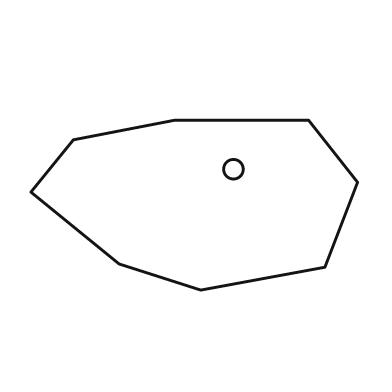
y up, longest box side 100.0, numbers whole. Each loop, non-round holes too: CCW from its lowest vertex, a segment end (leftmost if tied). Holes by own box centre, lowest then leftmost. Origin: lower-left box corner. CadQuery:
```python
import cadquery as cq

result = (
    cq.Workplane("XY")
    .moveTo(52.0, 0.0)
    .lineTo(90.0, 7.0)
    .lineTo(100.0, 33.0)
    .lineTo(85.0, 52.0)
    .lineTo(44.0, 52.0)
    .lineTo(13.0, 46.0)
    .lineTo(0.0, 30.0)
    .lineTo(27.0, 8.0)
    .close()
    .moveTo(62.0, 37.0)
    .circle(3.0)
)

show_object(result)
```